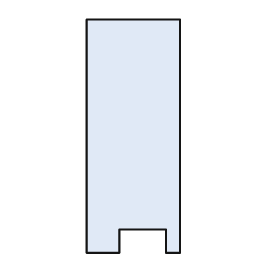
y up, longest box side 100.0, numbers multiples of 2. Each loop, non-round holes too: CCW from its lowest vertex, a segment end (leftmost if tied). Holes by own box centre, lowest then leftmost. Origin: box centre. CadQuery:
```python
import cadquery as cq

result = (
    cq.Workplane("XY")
    .moveTo(-20.0, -50.0)
    .lineTo(-6.0, -50.0)
    .lineTo(-6.0, -40.0)
    .lineTo(14.0, -40.0)
    .lineTo(14.0, -50.0)
    .lineTo(20.0, -50.0)
    .lineTo(20.0, 50.0)
    .lineTo(-20.0, 50.0)
    .close()
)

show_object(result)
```